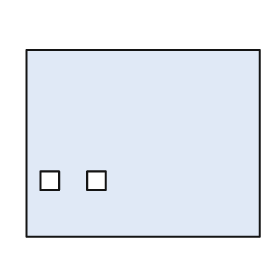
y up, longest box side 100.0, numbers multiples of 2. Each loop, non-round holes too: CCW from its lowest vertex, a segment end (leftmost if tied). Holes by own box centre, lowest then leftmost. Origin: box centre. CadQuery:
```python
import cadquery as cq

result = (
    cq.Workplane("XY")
    .moveTo(-50.0, -40.0)
    .lineTo(50.0, -40.0)
    .lineTo(50.0, 40.0)
    .lineTo(-50.0, 40.0)
    .close()
    .moveTo(-44.0, -20.0)
    .lineTo(-36.0, -20.0)
    .lineTo(-36.0, -12.0)
    .lineTo(-44.0, -12.0)
    .close()
    .moveTo(-24.0, -20.0)
    .lineTo(-16.0, -20.0)
    .lineTo(-16.0, -12.0)
    .lineTo(-24.0, -12.0)
    .close()
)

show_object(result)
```